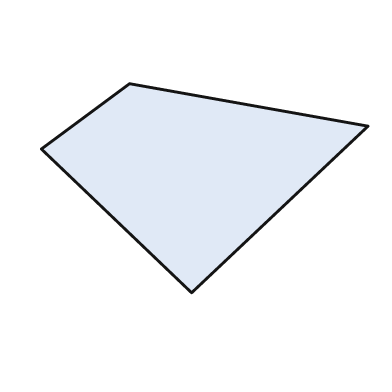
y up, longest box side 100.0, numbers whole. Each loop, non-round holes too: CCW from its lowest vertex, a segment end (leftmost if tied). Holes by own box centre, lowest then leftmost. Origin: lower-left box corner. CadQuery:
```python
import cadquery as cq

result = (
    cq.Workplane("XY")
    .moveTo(46.0, 0.0)
    .lineTo(100.0, 51.0)
    .lineTo(27.0, 64.0)
    .lineTo(0.0, 44.0)
    .close()
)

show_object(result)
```